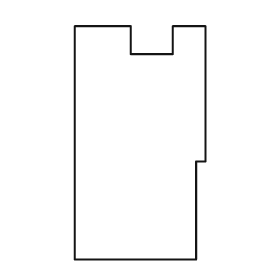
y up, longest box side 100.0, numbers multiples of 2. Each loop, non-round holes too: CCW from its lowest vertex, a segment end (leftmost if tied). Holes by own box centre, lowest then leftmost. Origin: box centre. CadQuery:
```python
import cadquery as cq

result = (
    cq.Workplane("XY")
    .moveTo(-28.0, -50.0)
    .lineTo(24.0, -50.0)
    .lineTo(24.0, -8.0)
    .lineTo(28.0, -8.0)
    .lineTo(28.0, 50.0)
    .lineTo(14.0, 50.0)
    .lineTo(14.0, 38.0)
    .lineTo(-4.0, 38.0)
    .lineTo(-4.0, 50.0)
    .lineTo(-28.0, 50.0)
    .close()
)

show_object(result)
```